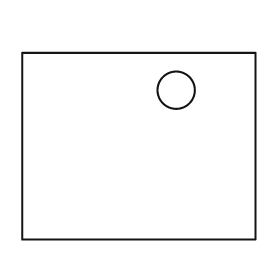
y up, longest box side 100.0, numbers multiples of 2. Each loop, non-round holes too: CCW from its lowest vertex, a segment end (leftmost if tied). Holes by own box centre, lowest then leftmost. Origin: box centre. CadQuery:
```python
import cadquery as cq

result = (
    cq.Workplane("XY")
    .moveTo(-50.0, -40.0)
    .lineTo(50.0, -40.0)
    .lineTo(50.0, 40.0)
    .lineTo(-50.0, 40.0)
    .close()
    .moveTo(16.0, 24.0)
    .circle(8.0)
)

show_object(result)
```